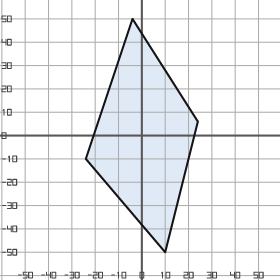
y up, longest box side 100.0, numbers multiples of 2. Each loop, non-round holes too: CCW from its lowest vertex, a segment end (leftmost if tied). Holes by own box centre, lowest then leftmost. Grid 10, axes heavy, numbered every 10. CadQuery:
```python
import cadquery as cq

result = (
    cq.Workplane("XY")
    .moveTo(10.0, -50.0)
    .lineTo(24.0, 6.0)
    .lineTo(-4.0, 50.0)
    .lineTo(-24.0, -10.0)
    .close()
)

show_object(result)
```